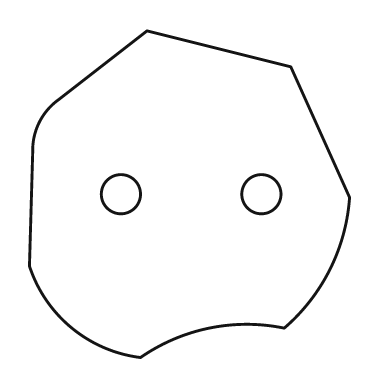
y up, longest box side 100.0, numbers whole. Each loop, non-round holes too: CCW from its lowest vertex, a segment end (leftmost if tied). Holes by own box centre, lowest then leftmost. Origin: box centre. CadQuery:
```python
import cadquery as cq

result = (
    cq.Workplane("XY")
    .moveTo(-15.0, -50.0)
    .threePointArc((6.0, -41.0), (29.0, -41.0))
    .threePointArc((43.0, -23.0), (49.0, -1.0))
    .lineTo(31.0, 39.0)
    .lineTo(-13.0, 50.0)
    .lineTo(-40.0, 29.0)
    .threePointArc((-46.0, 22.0), (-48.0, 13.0))
    .lineTo(-49.0, -22.0)
    .threePointArc((-36.0, -41.0), (-15.0, -50.0))
    .close()
    .moveTo(-21.0, 0.0)
    .circle(6.0)
    .moveTo(22.0, 0.0)
    .circle(6.0)
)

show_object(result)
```